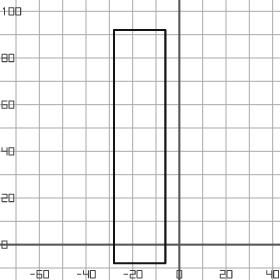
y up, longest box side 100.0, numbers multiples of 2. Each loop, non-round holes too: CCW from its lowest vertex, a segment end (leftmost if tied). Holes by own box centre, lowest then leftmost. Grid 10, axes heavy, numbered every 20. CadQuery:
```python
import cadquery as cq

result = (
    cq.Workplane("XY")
    .moveTo(-28.0, -8.0)
    .lineTo(-6.0, -8.0)
    .lineTo(-6.0, 92.0)
    .lineTo(-28.0, 92.0)
    .close()
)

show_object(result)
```